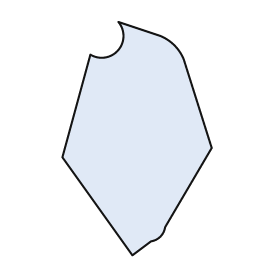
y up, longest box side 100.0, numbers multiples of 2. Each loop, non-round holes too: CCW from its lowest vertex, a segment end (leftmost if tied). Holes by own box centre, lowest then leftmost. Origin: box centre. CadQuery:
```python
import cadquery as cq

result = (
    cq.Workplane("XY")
    .moveTo(-2.0, -50.0)
    .lineTo(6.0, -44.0)
    .threePointArc((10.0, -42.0), (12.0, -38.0))
    .lineTo(32.0, -4.0)
    .lineTo(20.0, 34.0)
    .threePointArc((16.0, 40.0), (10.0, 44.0))
    .lineTo(-8.0, 50.0)
    .threePointArc((-8.0, 38.0), (-20.0, 36.0))
    .lineTo(-32.0, -8.0)
    .close()
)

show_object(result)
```